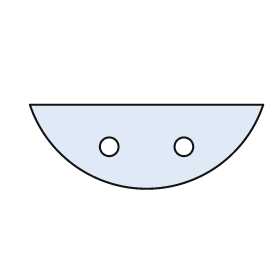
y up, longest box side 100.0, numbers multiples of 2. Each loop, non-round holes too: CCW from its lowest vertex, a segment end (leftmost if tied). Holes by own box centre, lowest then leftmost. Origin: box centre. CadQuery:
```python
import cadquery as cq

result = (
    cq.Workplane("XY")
    .moveTo(-50.0, 18.0)
    .threePointArc((0.0, -18.0), (50.0, 18.0))
    .close()
    .moveTo(-16.0, 0.0)
    .circle(4.0)
    .moveTo(16.0, 0.0)
    .circle(4.0)
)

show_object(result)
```